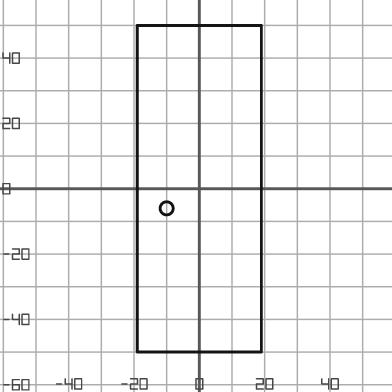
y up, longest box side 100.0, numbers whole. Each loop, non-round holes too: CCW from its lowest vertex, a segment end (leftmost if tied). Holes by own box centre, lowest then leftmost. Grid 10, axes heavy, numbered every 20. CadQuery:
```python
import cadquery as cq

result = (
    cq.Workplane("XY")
    .moveTo(-19.0, -50.0)
    .lineTo(19.0, -50.0)
    .lineTo(19.0, 50.0)
    .lineTo(-19.0, 50.0)
    .close()
    .moveTo(-10.0, -6.0)
    .circle(2.0)
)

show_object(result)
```